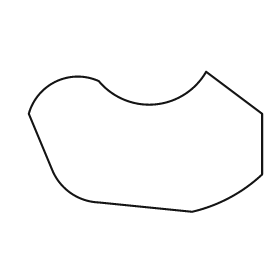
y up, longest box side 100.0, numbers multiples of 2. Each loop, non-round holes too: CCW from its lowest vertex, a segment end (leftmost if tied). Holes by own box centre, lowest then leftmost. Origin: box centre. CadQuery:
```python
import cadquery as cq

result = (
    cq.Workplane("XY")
    .moveTo(20.0, -30.0)
    .threePointArc((36.0, -24.0), (50.0, -14.0))
    .lineTo(50.0, 12.0)
    .lineTo(26.0, 30.0)
    .threePointArc((4.0, 16.0), (-20.0, 26.0))
    .threePointArc((-38.0, 26.0), (-50.0, 12.0))
    .lineTo(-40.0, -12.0)
    .threePointArc((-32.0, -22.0), (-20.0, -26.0))
    .close()
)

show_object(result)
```